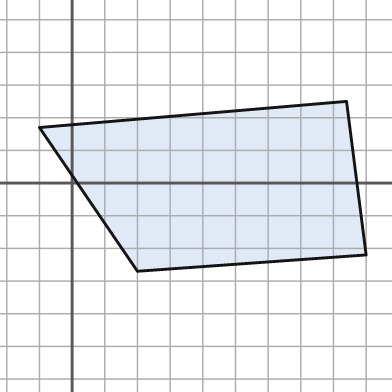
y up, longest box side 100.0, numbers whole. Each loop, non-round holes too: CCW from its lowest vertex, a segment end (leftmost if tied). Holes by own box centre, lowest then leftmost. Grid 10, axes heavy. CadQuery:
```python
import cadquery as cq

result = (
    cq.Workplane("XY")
    .moveTo(20.0, -27.0)
    .lineTo(90.0, -22.0)
    .lineTo(84.0, 25.0)
    .lineTo(-10.0, 17.0)
    .close()
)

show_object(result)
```